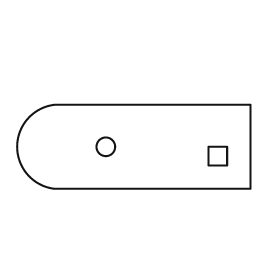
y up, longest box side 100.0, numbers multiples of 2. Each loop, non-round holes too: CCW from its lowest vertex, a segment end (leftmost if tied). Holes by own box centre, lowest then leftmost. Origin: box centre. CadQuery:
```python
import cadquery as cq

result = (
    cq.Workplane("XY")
    .moveTo(-34.0, -18.0)
    .lineTo(50.0, -18.0)
    .lineTo(50.0, 18.0)
    .lineTo(-34.0, 18.0)
    .threePointArc((-50.0, 0.0), (-34.0, -18.0))
    .close()
    .moveTo(32.0, -8.0)
    .lineTo(40.0, -8.0)
    .lineTo(40.0, 0.0)
    .lineTo(32.0, 0.0)
    .close()
    .moveTo(-12.0, 0.0)
    .circle(4.0)
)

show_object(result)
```